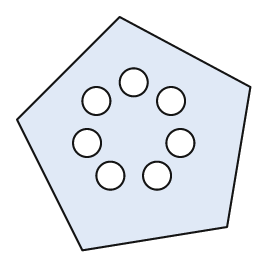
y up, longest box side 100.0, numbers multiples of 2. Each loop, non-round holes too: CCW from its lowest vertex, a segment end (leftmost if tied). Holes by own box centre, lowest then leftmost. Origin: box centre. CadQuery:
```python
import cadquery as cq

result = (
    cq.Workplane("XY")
    .moveTo(-22.0, -50.0)
    .lineTo(40.0, -40.0)
    .lineTo(50.0, 20.0)
    .lineTo(-6.0, 50.0)
    .lineTo(-50.0, 6.0)
    .close()
    .moveTo(-10.0, -18.0)
    .circle(6.0)
    .moveTo(10.0, -18.0)
    .circle(6.0)
    .moveTo(-20.0, -4.0)
    .circle(6.0)
    .moveTo(20.0, -4.0)
    .circle(6.0)
    .moveTo(-16.0, 14.0)
    .circle(6.0)
    .moveTo(16.0, 14.0)
    .circle(6.0)
    .moveTo(0.0, 22.0)
    .circle(6.0)
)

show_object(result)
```